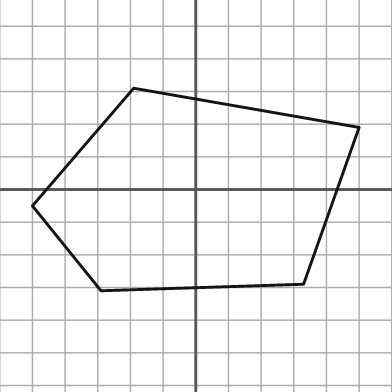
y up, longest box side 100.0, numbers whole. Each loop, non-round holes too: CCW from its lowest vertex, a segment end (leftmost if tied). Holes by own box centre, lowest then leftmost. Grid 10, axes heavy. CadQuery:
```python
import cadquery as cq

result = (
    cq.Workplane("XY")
    .moveTo(-29.0, -31.0)
    .lineTo(33.0, -29.0)
    .lineTo(50.0, 19.0)
    .lineTo(-19.0, 31.0)
    .lineTo(-50.0, -5.0)
    .close()
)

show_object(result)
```